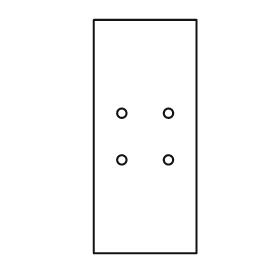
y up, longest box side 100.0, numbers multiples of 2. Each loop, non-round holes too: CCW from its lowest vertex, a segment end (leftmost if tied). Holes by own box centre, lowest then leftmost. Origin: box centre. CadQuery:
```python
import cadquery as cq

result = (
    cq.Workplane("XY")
    .moveTo(-22.0, -50.0)
    .lineTo(22.0, -50.0)
    .lineTo(22.0, 50.0)
    .lineTo(-22.0, 50.0)
    .close()
    .moveTo(-10.0, -10.0)
    .circle(2.0)
    .moveTo(10.0, -10.0)
    .circle(2.0)
    .moveTo(-10.0, 10.0)
    .circle(2.0)
    .moveTo(10.0, 10.0)
    .circle(2.0)
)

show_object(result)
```